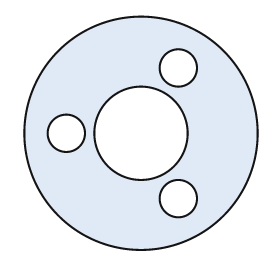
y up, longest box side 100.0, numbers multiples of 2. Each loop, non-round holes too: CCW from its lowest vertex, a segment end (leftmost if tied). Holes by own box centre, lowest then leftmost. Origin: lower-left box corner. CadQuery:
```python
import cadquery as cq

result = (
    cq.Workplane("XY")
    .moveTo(50.0, 50.0)
    .circle(50.0)
    .moveTo(66.0, 22.0)
    .circle(8.0)
    .moveTo(18.0, 50.0)
    .circle(8.0)
    .moveTo(50.0, 50.0)
    .circle(20.0)
    .moveTo(66.0, 78.0)
    .circle(8.0)
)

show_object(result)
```